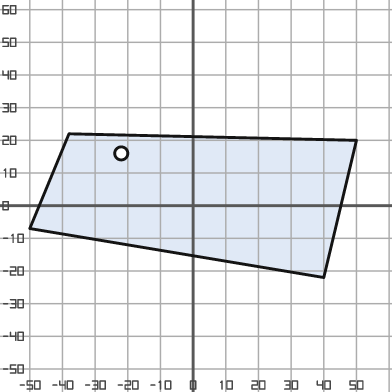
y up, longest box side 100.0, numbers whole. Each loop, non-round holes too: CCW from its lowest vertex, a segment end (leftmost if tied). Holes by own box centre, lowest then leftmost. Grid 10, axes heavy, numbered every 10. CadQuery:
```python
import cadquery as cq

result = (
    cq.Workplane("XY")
    .moveTo(40.0, -22.0)
    .lineTo(50.0, 20.0)
    .lineTo(-38.0, 22.0)
    .lineTo(-50.0, -7.0)
    .close()
    .moveTo(-22.0, 16.0)
    .circle(2.0)
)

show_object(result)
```